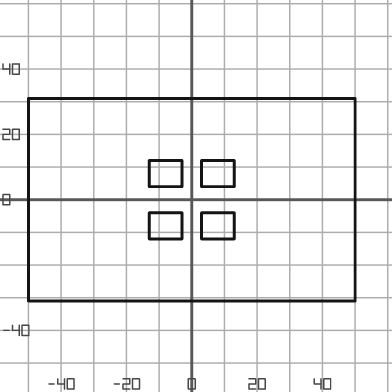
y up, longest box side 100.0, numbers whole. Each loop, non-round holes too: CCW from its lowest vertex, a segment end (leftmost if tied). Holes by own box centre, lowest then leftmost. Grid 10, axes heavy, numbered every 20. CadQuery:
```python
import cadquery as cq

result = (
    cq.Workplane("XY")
    .moveTo(-50.0, -31.0)
    .lineTo(50.0, -31.0)
    .lineTo(50.0, 31.0)
    .lineTo(-50.0, 31.0)
    .close()
    .moveTo(-13.0, -12.0)
    .lineTo(-3.0, -12.0)
    .lineTo(-3.0, -4.0)
    .lineTo(-13.0, -4.0)
    .close()
    .moveTo(3.0, -12.0)
    .lineTo(13.0, -12.0)
    .lineTo(13.0, -4.0)
    .lineTo(3.0, -4.0)
    .close()
    .moveTo(-13.0, 4.0)
    .lineTo(-3.0, 4.0)
    .lineTo(-3.0, 12.0)
    .lineTo(-13.0, 12.0)
    .close()
    .moveTo(3.0, 4.0)
    .lineTo(13.0, 4.0)
    .lineTo(13.0, 12.0)
    .lineTo(3.0, 12.0)
    .close()
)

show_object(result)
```